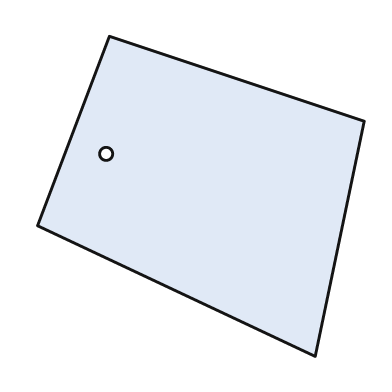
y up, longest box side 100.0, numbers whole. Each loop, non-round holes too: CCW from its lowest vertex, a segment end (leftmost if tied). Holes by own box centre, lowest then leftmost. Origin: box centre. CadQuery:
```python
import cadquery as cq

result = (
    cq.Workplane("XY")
    .moveTo(35.0, -49.0)
    .lineTo(50.0, 23.0)
    .lineTo(-28.0, 49.0)
    .lineTo(-50.0, -9.0)
    .close()
    .moveTo(-29.0, 13.0)
    .circle(2.0)
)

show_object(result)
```